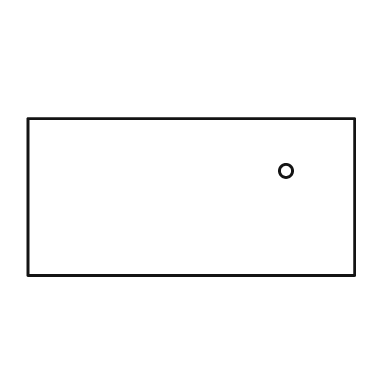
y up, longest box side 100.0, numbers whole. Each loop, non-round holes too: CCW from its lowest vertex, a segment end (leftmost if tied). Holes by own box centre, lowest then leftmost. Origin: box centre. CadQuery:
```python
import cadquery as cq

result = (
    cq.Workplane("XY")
    .moveTo(-50.0, -24.0)
    .lineTo(50.0, -24.0)
    .lineTo(50.0, 24.0)
    .lineTo(-50.0, 24.0)
    .close()
    .moveTo(29.0, 8.0)
    .circle(2.0)
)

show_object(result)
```